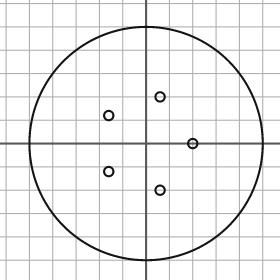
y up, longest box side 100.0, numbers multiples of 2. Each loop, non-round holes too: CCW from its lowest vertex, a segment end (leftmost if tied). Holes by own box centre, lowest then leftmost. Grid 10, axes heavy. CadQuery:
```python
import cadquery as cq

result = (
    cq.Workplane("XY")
    .moveTo(0.0, 0.0)
    .circle(50.0)
    .moveTo(6.0, -20.0)
    .circle(2.0)
    .moveTo(-16.0, -12.0)
    .circle(2.0)
    .moveTo(20.0, 0.0)
    .circle(2.0)
    .moveTo(-16.0, 12.0)
    .circle(2.0)
    .moveTo(6.0, 20.0)
    .circle(2.0)
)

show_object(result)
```